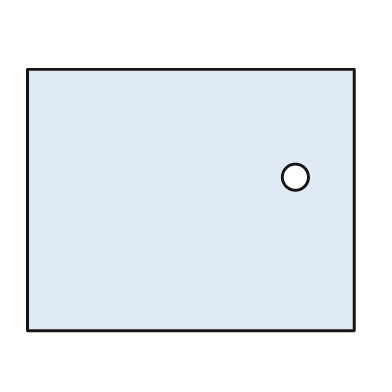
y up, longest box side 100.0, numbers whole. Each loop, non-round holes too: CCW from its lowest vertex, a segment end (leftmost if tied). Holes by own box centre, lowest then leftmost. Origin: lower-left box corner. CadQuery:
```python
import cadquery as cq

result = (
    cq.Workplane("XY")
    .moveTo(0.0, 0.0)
    .lineTo(100.0, 0.0)
    .lineTo(100.0, 80.0)
    .lineTo(0.0, 80.0)
    .close()
    .moveTo(82.0, 47.0)
    .circle(4.0)
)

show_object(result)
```